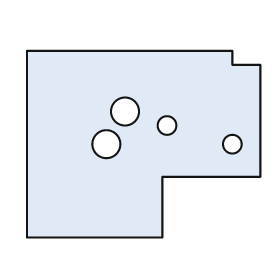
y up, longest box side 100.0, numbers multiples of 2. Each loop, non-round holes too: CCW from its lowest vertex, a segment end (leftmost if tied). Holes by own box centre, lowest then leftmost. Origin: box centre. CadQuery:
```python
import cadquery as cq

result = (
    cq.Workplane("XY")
    .moveTo(-50.0, -40.0)
    .lineTo(8.0, -40.0)
    .lineTo(8.0, -14.0)
    .lineTo(50.0, -14.0)
    .lineTo(50.0, 34.0)
    .lineTo(38.0, 34.0)
    .lineTo(38.0, 40.0)
    .lineTo(-50.0, 40.0)
    .close()
    .moveTo(-16.0, 0.0)
    .circle(6.0)
    .moveTo(38.0, 0.0)
    .circle(4.0)
    .moveTo(10.0, 8.0)
    .circle(4.0)
    .moveTo(-8.0, 14.0)
    .circle(6.0)
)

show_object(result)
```